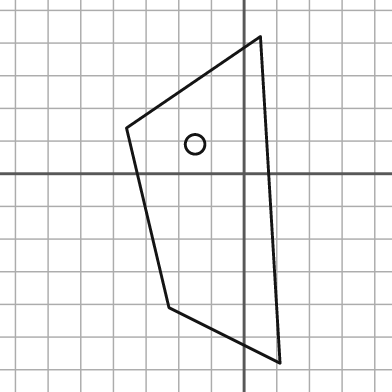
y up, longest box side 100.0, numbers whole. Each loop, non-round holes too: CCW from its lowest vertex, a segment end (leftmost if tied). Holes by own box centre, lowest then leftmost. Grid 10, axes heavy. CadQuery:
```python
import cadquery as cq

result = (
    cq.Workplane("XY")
    .moveTo(11.0, -58.0)
    .lineTo(5.0, 42.0)
    .lineTo(-36.0, 14.0)
    .lineTo(-23.0, -41.0)
    .close()
    .moveTo(-15.0, 9.0)
    .circle(3.0)
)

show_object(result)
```